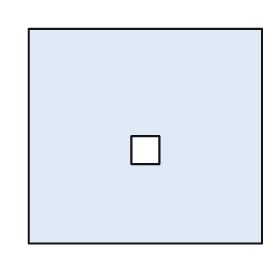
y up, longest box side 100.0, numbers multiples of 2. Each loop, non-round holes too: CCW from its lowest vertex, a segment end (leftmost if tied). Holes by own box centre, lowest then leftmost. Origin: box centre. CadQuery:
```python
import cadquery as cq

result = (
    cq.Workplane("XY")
    .moveTo(-50.0, -46.0)
    .lineTo(50.0, -46.0)
    .lineTo(50.0, 46.0)
    .lineTo(-50.0, 46.0)
    .close()
    .moveTo(-6.0, -12.0)
    .lineTo(6.0, -12.0)
    .lineTo(6.0, 0.0)
    .lineTo(-6.0, 0.0)
    .close()
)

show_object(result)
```